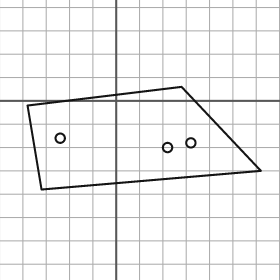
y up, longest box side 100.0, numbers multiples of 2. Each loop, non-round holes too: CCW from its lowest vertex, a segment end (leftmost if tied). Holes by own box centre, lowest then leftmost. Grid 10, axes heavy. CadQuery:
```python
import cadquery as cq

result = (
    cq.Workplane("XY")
    .moveTo(-32.0, -38.0)
    .lineTo(62.0, -30.0)
    .lineTo(28.0, 6.0)
    .lineTo(-38.0, -2.0)
    .close()
    .moveTo(22.0, -20.0)
    .circle(2.0)
    .moveTo(32.0, -18.0)
    .circle(2.0)
    .moveTo(-24.0, -16.0)
    .circle(2.0)
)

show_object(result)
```